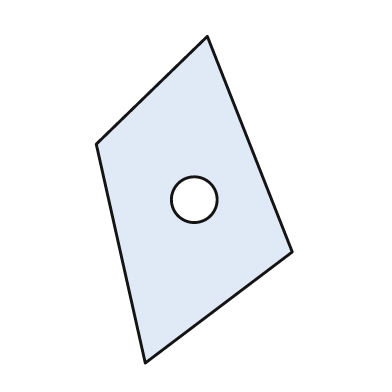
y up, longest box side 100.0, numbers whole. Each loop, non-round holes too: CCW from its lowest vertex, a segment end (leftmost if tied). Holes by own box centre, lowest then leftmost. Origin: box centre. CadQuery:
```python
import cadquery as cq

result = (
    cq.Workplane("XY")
    .moveTo(-15.0, -50.0)
    .lineTo(30.0, -16.0)
    .lineTo(4.0, 50.0)
    .lineTo(-30.0, 17.0)
    .close()
    .moveTo(0.0, 0.0)
    .circle(7.0)
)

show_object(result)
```